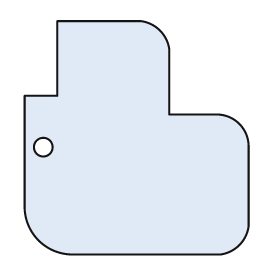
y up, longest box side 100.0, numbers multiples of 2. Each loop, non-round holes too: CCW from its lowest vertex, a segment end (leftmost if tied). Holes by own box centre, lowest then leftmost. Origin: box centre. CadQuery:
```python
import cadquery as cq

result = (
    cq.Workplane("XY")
    .moveTo(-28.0, -50.0)
    .lineTo(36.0, -50.0)
    .threePointArc((44.0, -46.0), (48.0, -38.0))
    .lineTo(48.0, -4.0)
    .threePointArc((44.0, 6.0), (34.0, 10.0))
    .lineTo(14.0, 10.0)
    .lineTo(14.0, 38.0)
    .threePointArc((10.0, 46.0), (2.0, 50.0))
    .lineTo(-34.0, 50.0)
    .lineTo(-34.0, 18.0)
    .lineTo(-48.0, 18.0)
    .lineTo(-48.0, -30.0)
    .threePointArc((-42.0, -44.0), (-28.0, -50.0))
    .close()
    .moveTo(-40.0, -4.0)
    .circle(4.0)
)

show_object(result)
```